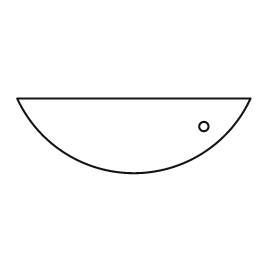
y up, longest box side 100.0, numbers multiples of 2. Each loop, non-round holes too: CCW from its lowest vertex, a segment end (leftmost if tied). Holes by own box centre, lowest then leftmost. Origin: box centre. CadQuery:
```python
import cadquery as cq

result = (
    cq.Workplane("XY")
    .moveTo(-50.0, 16.0)
    .threePointArc((0.0, -16.0), (50.0, 16.0))
    .close()
    .moveTo(30.0, 4.0)
    .circle(2.0)
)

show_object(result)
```